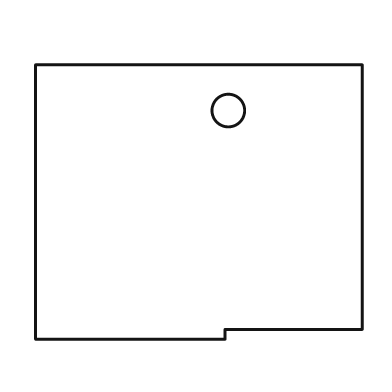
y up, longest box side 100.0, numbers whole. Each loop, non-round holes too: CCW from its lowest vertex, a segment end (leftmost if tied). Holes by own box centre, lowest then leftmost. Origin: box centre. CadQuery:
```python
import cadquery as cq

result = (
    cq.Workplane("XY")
    .moveTo(-50.0, -42.0)
    .lineTo(8.0, -42.0)
    .lineTo(8.0, -39.0)
    .lineTo(50.0, -39.0)
    .lineTo(50.0, 42.0)
    .lineTo(-50.0, 42.0)
    .close()
    .moveTo(9.0, 28.0)
    .circle(5.0)
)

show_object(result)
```